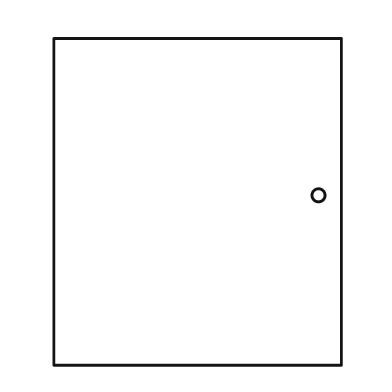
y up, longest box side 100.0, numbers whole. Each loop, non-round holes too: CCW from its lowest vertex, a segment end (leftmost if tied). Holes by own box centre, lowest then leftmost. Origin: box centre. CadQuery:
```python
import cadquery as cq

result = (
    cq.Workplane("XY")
    .moveTo(-44.0, -50.0)
    .lineTo(44.0, -50.0)
    .lineTo(44.0, 50.0)
    .lineTo(-44.0, 50.0)
    .close()
    .moveTo(37.0, 2.0)
    .circle(2.0)
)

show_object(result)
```